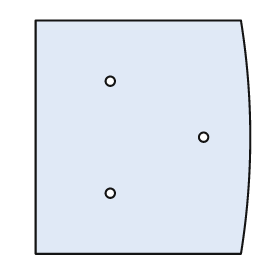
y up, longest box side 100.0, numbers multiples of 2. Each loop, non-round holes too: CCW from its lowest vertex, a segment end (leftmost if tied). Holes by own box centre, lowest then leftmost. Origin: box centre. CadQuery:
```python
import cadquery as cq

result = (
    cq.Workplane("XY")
    .moveTo(-46.0, -50.0)
    .lineTo(42.0, -50.0)
    .threePointArc((46.0, 0.0), (42.0, 50.0))
    .lineTo(-46.0, 50.0)
    .close()
    .moveTo(-14.0, -24.0)
    .circle(2.0)
    .moveTo(26.0, 0.0)
    .circle(2.0)
    .moveTo(-14.0, 24.0)
    .circle(2.0)
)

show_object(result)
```